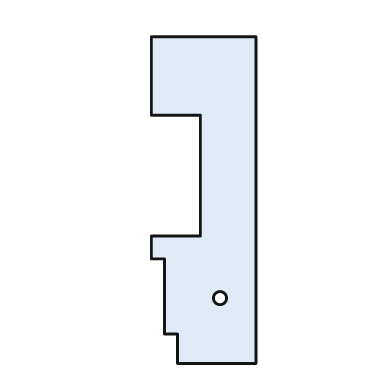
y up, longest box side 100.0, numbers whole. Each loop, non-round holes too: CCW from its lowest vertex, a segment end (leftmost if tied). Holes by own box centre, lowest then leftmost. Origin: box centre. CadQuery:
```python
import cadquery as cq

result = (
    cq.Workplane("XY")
    .moveTo(-8.0, -50.0)
    .lineTo(16.0, -50.0)
    .lineTo(16.0, 50.0)
    .lineTo(-16.0, 50.0)
    .lineTo(-16.0, 26.0)
    .lineTo(-1.0, 26.0)
    .lineTo(-1.0, -11.0)
    .lineTo(-16.0, -11.0)
    .lineTo(-16.0, -18.0)
    .lineTo(-12.0, -18.0)
    .lineTo(-12.0, -41.0)
    .lineTo(-8.0, -41.0)
    .close()
    .moveTo(5.0, -30.0)
    .circle(2.0)
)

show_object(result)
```